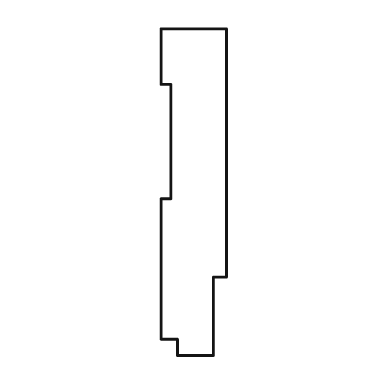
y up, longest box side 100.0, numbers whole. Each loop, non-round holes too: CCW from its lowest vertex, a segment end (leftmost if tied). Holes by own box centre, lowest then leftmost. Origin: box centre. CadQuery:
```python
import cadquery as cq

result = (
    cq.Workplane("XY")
    .moveTo(-5.0, -50.0)
    .lineTo(6.0, -50.0)
    .lineTo(6.0, -26.0)
    .lineTo(10.0, -26.0)
    .lineTo(10.0, 50.0)
    .lineTo(-10.0, 50.0)
    .lineTo(-10.0, 33.0)
    .lineTo(-7.0, 33.0)
    .lineTo(-7.0, -2.0)
    .lineTo(-10.0, -2.0)
    .lineTo(-10.0, -45.0)
    .lineTo(-5.0, -45.0)
    .close()
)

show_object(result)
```